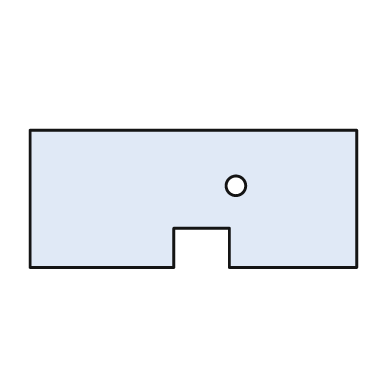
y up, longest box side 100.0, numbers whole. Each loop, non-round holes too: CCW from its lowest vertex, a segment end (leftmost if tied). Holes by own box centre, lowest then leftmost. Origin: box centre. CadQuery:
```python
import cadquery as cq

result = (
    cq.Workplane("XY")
    .moveTo(-50.0, -21.0)
    .lineTo(-6.0, -21.0)
    .lineTo(-6.0, -9.0)
    .lineTo(11.0, -9.0)
    .lineTo(11.0, -21.0)
    .lineTo(50.0, -21.0)
    .lineTo(50.0, 21.0)
    .lineTo(-50.0, 21.0)
    .close()
    .moveTo(13.0, 4.0)
    .circle(3.0)
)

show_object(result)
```